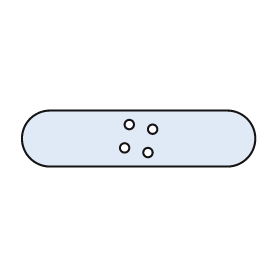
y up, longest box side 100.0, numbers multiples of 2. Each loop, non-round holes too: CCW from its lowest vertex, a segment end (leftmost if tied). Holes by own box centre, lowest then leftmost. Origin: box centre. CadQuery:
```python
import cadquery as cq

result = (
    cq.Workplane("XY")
    .moveTo(-38.0, -12.0)
    .lineTo(38.0, -12.0)
    .threePointArc((50.0, 0.0), (38.0, 12.0))
    .lineTo(-38.0, 12.0)
    .threePointArc((-50.0, 0.0), (-38.0, -12.0))
    .close()
    .moveTo(4.0, -6.0)
    .circle(2.0)
    .moveTo(-6.0, -4.0)
    .circle(2.0)
    .moveTo(6.0, 4.0)
    .circle(2.0)
    .moveTo(-4.0, 6.0)
    .circle(2.0)
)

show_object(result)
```